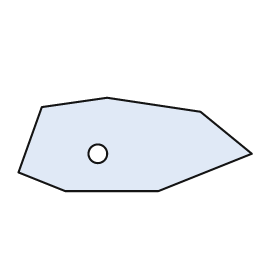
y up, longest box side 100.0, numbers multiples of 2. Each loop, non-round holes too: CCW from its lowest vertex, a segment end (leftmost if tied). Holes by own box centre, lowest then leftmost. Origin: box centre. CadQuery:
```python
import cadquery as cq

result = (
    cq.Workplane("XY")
    .moveTo(-30.0, -20.0)
    .lineTo(10.0, -20.0)
    .lineTo(50.0, -4.0)
    .lineTo(28.0, 14.0)
    .lineTo(-12.0, 20.0)
    .lineTo(-40.0, 16.0)
    .lineTo(-50.0, -12.0)
    .close()
    .moveTo(-16.0, -4.0)
    .circle(4.0)
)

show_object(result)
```